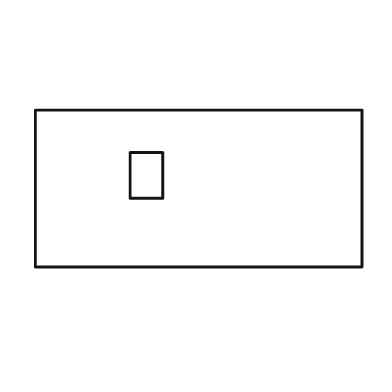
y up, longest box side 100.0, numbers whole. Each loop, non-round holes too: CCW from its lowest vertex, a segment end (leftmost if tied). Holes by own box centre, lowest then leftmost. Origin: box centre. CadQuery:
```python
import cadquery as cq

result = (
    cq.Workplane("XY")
    .moveTo(-50.0, -24.0)
    .lineTo(50.0, -24.0)
    .lineTo(50.0, 24.0)
    .lineTo(-50.0, 24.0)
    .close()
    .moveTo(-21.0, -3.0)
    .lineTo(-11.0, -3.0)
    .lineTo(-11.0, 11.0)
    .lineTo(-21.0, 11.0)
    .close()
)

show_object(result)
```